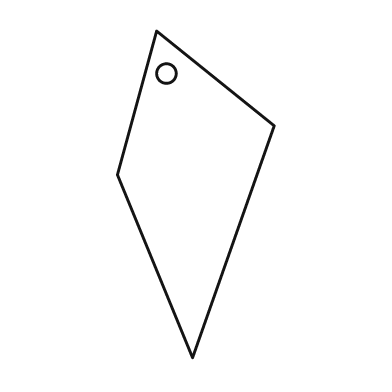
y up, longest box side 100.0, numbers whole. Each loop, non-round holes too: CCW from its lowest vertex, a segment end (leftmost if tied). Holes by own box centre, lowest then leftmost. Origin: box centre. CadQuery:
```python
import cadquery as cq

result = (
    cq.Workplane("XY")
    .moveTo(-1.0, -50.0)
    .lineTo(24.0, 21.0)
    .lineTo(-12.0, 50.0)
    .lineTo(-24.0, 6.0)
    .close()
    .moveTo(-9.0, 37.0)
    .circle(3.0)
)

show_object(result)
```